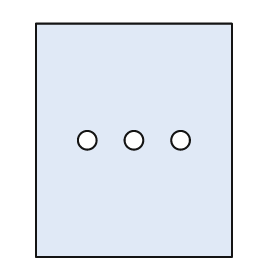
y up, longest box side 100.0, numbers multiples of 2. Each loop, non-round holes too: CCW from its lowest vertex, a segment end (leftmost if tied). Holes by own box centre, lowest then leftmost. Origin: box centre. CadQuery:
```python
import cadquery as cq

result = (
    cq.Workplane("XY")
    .moveTo(-42.0, -50.0)
    .lineTo(42.0, -50.0)
    .lineTo(42.0, 50.0)
    .lineTo(-42.0, 50.0)
    .close()
    .moveTo(-20.0, 0.0)
    .circle(4.0)
    .moveTo(0.0, 0.0)
    .circle(4.0)
    .moveTo(20.0, 0.0)
    .circle(4.0)
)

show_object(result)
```